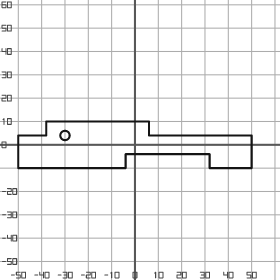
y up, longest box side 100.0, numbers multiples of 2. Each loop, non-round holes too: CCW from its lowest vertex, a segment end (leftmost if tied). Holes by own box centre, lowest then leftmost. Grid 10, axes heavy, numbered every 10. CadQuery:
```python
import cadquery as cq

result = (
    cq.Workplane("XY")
    .moveTo(-50.0, -10.0)
    .lineTo(-4.0, -10.0)
    .lineTo(-4.0, -4.0)
    .lineTo(32.0, -4.0)
    .lineTo(32.0, -10.0)
    .lineTo(50.0, -10.0)
    .lineTo(50.0, 4.0)
    .lineTo(6.0, 4.0)
    .lineTo(6.0, 10.0)
    .lineTo(-38.0, 10.0)
    .lineTo(-38.0, 4.0)
    .lineTo(-50.0, 4.0)
    .close()
    .moveTo(-30.0, 4.0)
    .circle(2.0)
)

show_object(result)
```